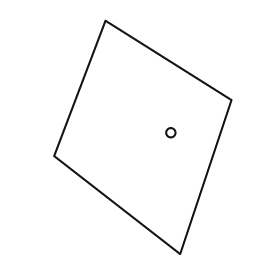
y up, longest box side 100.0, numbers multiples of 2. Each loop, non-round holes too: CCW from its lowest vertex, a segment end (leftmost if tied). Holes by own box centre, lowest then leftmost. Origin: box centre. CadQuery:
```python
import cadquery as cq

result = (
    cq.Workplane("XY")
    .moveTo(16.0, -50.0)
    .lineTo(38.0, 16.0)
    .lineTo(-16.0, 50.0)
    .lineTo(-38.0, -8.0)
    .close()
    .moveTo(12.0, 2.0)
    .circle(2.0)
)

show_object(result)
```